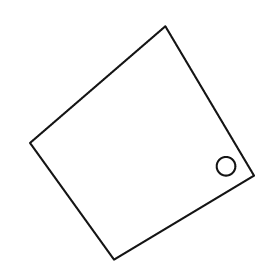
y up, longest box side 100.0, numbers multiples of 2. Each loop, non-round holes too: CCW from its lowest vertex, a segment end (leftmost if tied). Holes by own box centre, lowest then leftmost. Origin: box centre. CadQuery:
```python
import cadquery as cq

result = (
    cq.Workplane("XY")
    .moveTo(-12.0, -50.0)
    .lineTo(48.0, -14.0)
    .lineTo(10.0, 50.0)
    .lineTo(-48.0, 0.0)
    .close()
    .moveTo(36.0, -10.0)
    .circle(4.0)
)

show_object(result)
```